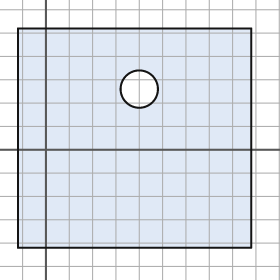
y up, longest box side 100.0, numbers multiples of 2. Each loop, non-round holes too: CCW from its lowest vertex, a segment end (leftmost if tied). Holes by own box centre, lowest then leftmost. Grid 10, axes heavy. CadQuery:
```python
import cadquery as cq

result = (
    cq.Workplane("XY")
    .moveTo(-12.0, -42.0)
    .lineTo(88.0, -42.0)
    .lineTo(88.0, 52.0)
    .lineTo(-12.0, 52.0)
    .close()
    .moveTo(40.0, 26.0)
    .circle(8.0)
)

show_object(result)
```